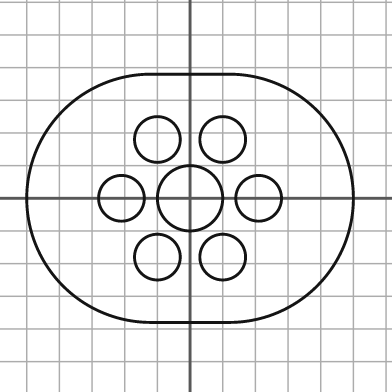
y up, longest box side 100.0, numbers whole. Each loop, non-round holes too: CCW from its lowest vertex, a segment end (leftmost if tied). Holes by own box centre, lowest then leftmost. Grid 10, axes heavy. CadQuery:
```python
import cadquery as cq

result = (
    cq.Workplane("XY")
    .moveTo(-12.0, -38.0)
    .lineTo(12.0, -38.0)
    .threePointArc((50.0, 0.0), (12.0, 38.0))
    .lineTo(-12.0, 38.0)
    .threePointArc((-50.0, 0.0), (-12.0, -38.0))
    .close()
    .moveTo(-10.0, -18.0)
    .circle(7.0)
    .moveTo(10.0, -18.0)
    .circle(7.0)
    .moveTo(-21.0, 0.0)
    .circle(7.0)
    .moveTo(0.0, 0.0)
    .circle(10.0)
    .moveTo(21.0, 0.0)
    .circle(7.0)
    .moveTo(-10.0, 18.0)
    .circle(7.0)
    .moveTo(10.0, 18.0)
    .circle(7.0)
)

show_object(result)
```